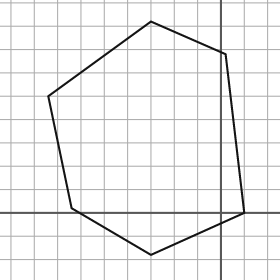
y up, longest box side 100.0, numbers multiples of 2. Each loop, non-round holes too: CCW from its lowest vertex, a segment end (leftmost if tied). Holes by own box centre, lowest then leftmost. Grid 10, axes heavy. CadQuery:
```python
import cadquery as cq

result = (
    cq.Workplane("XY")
    .moveTo(-30.0, -18.0)
    .lineTo(10.0, 0.0)
    .lineTo(2.0, 68.0)
    .lineTo(-30.0, 82.0)
    .lineTo(-74.0, 50.0)
    .lineTo(-64.0, 2.0)
    .close()
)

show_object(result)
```